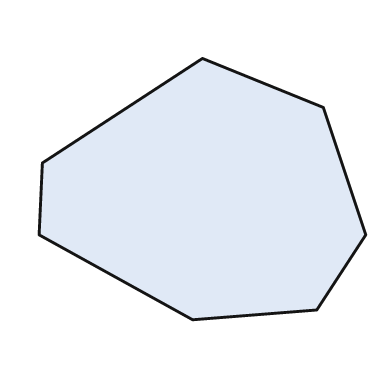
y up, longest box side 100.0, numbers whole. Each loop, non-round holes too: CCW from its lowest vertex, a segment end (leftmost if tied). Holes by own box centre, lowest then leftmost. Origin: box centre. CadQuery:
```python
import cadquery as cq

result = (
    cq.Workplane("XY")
    .moveTo(-3.0, -40.0)
    .lineTo(35.0, -37.0)
    .lineTo(50.0, -14.0)
    .lineTo(37.0, 25.0)
    .lineTo(0.0, 40.0)
    .lineTo(-49.0, 8.0)
    .lineTo(-50.0, -14.0)
    .close()
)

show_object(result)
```